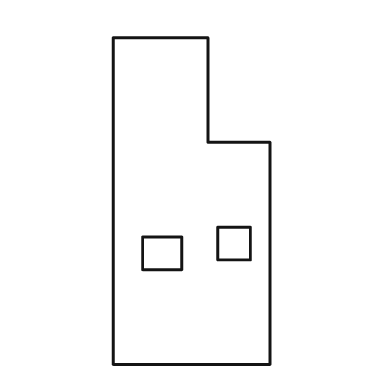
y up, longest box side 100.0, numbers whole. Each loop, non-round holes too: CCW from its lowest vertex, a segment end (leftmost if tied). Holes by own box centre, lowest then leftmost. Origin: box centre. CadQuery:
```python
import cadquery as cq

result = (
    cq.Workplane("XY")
    .moveTo(-24.0, -50.0)
    .lineTo(24.0, -50.0)
    .lineTo(24.0, 18.0)
    .lineTo(5.0, 18.0)
    .lineTo(5.0, 50.0)
    .lineTo(-24.0, 50.0)
    .close()
    .moveTo(-15.0, -21.0)
    .lineTo(-3.0, -21.0)
    .lineTo(-3.0, -11.0)
    .lineTo(-15.0, -11.0)
    .close()
    .moveTo(8.0, -18.0)
    .lineTo(18.0, -18.0)
    .lineTo(18.0, -8.0)
    .lineTo(8.0, -8.0)
    .close()
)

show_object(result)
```